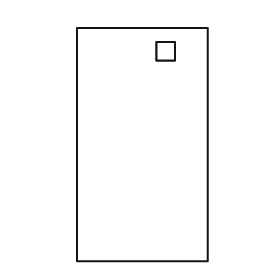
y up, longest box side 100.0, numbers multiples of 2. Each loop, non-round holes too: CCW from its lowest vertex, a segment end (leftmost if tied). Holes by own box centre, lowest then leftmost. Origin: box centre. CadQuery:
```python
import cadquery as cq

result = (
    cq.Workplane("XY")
    .moveTo(-28.0, -50.0)
    .lineTo(28.0, -50.0)
    .lineTo(28.0, 50.0)
    .lineTo(-28.0, 50.0)
    .close()
    .moveTo(6.0, 36.0)
    .lineTo(14.0, 36.0)
    .lineTo(14.0, 44.0)
    .lineTo(6.0, 44.0)
    .close()
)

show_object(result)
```